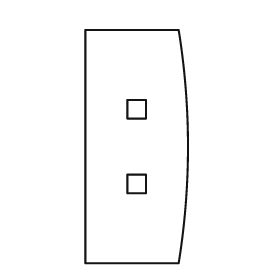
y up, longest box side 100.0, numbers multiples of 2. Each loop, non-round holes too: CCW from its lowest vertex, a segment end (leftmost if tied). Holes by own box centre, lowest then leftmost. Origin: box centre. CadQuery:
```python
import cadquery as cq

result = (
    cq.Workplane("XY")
    .moveTo(-22.0, -50.0)
    .lineTo(18.0, -50.0)
    .threePointArc((22.0, 0.0), (18.0, 50.0))
    .lineTo(-22.0, 50.0)
    .close()
    .moveTo(-4.0, -20.0)
    .lineTo(4.0, -20.0)
    .lineTo(4.0, -12.0)
    .lineTo(-4.0, -12.0)
    .close()
    .moveTo(-4.0, 12.0)
    .lineTo(4.0, 12.0)
    .lineTo(4.0, 20.0)
    .lineTo(-4.0, 20.0)
    .close()
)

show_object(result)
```